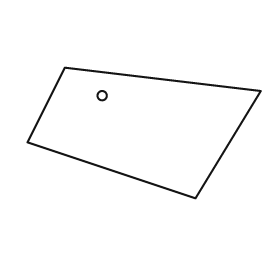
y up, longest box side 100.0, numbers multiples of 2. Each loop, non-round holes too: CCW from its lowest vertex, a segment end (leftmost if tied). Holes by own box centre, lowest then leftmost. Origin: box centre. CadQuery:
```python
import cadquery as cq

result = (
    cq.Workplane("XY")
    .moveTo(22.0, -28.0)
    .lineTo(50.0, 18.0)
    .lineTo(-34.0, 28.0)
    .lineTo(-50.0, -4.0)
    .close()
    .moveTo(-18.0, 16.0)
    .circle(2.0)
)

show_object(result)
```